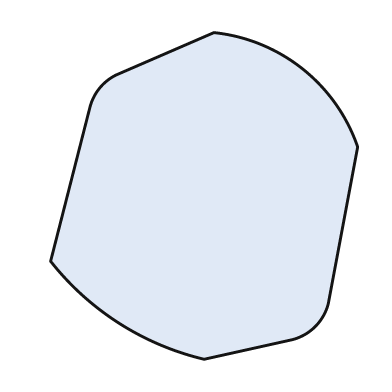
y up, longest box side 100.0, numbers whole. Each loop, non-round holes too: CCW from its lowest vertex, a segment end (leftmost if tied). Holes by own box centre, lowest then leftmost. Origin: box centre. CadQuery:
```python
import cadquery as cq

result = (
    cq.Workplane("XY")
    .moveTo(0.0, -50.0)
    .lineTo(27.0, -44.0)
    .threePointArc((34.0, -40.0), (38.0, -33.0))
    .lineTo(47.0, 15.0)
    .threePointArc((30.0, 39.0), (3.0, 50.0))
    .lineTo(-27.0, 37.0)
    .threePointArc((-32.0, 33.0), (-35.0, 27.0))
    .lineTo(-47.0, -20.0)
    .threePointArc((-26.0, -39.0), (0.0, -50.0))
    .close()
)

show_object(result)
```